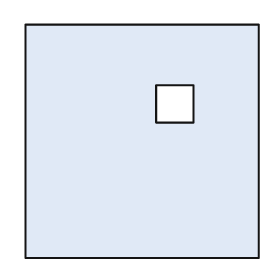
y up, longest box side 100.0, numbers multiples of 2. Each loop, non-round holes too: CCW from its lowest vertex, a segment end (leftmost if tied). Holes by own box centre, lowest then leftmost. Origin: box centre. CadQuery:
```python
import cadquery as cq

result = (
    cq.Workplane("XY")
    .moveTo(-50.0, -50.0)
    .lineTo(50.0, -50.0)
    .lineTo(50.0, 50.0)
    .lineTo(-50.0, 50.0)
    .close()
    .moveTo(6.0, 8.0)
    .lineTo(22.0, 8.0)
    .lineTo(22.0, 24.0)
    .lineTo(6.0, 24.0)
    .close()
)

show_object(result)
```